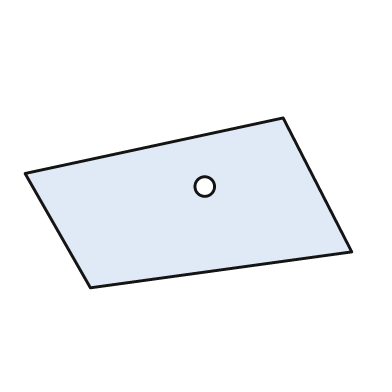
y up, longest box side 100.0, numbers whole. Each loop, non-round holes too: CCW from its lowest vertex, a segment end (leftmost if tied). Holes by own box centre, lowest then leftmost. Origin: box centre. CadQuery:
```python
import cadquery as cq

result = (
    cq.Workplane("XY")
    .moveTo(-30.0, -26.0)
    .lineTo(50.0, -15.0)
    .lineTo(29.0, 26.0)
    .lineTo(-50.0, 9.0)
    .close()
    .moveTo(5.0, 5.0)
    .circle(3.0)
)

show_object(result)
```